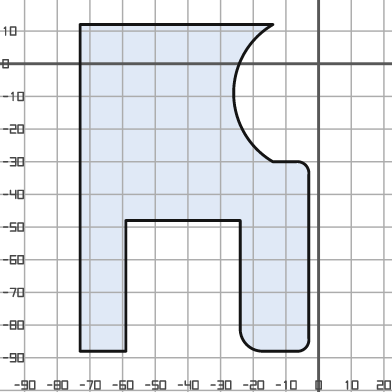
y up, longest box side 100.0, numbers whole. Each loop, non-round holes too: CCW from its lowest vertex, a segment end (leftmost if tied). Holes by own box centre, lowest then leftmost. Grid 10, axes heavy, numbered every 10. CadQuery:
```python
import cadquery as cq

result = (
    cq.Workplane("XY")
    .moveTo(-73.0, -88.0)
    .lineTo(-59.0, -88.0)
    .lineTo(-59.0, -48.0)
    .lineTo(-24.0, -48.0)
    .lineTo(-24.0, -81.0)
    .threePointArc((-22.0, -86.0), (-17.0, -88.0))
    .lineTo(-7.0, -88.0)
    .threePointArc((-4.0, -87.0), (-3.0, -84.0))
    .lineTo(-3.0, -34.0)
    .threePointArc((-4.0, -31.0), (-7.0, -30.0))
    .lineTo(-14.0, -30.0)
    .threePointArc((-26.0, -9.0), (-14.0, 12.0))
    .lineTo(-73.0, 12.0)
    .close()
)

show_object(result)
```